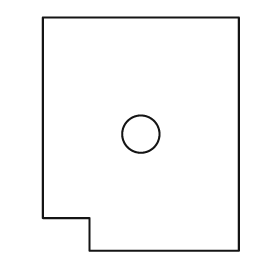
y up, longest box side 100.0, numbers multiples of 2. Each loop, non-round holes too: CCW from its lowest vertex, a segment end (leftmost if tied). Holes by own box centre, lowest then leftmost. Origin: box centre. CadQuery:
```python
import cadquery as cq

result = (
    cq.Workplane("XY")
    .moveTo(-22.0, -50.0)
    .lineTo(42.0, -50.0)
    .lineTo(42.0, 50.0)
    .lineTo(-42.0, 50.0)
    .lineTo(-42.0, -36.0)
    .lineTo(-22.0, -36.0)
    .close()
    .moveTo(0.0, 0.0)
    .circle(8.0)
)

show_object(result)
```